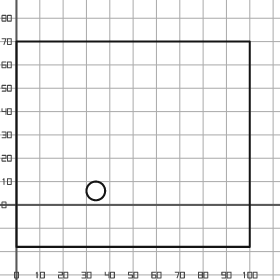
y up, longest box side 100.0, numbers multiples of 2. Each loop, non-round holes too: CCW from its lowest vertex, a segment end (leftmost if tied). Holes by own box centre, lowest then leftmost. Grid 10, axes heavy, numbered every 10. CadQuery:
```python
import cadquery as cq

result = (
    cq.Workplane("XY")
    .moveTo(0.0, -18.0)
    .lineTo(100.0, -18.0)
    .lineTo(100.0, 70.0)
    .lineTo(0.0, 70.0)
    .close()
    .moveTo(34.0, 6.0)
    .circle(4.0)
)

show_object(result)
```